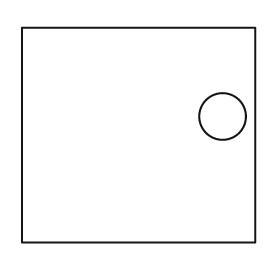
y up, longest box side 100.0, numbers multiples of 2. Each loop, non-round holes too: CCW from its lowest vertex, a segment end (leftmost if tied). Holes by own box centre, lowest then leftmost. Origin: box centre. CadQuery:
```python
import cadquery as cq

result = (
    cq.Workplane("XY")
    .moveTo(-50.0, -46.0)
    .lineTo(50.0, -46.0)
    .lineTo(50.0, 46.0)
    .lineTo(-50.0, 46.0)
    .close()
    .moveTo(36.0, 8.0)
    .circle(10.0)
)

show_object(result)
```